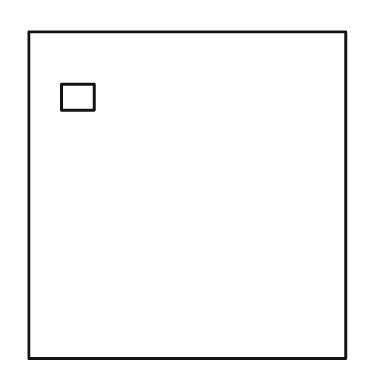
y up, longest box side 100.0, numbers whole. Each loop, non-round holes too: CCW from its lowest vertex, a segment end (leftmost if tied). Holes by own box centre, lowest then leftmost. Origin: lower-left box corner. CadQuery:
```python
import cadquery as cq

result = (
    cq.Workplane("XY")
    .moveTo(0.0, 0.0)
    .lineTo(97.0, 0.0)
    .lineTo(97.0, 100.0)
    .lineTo(0.0, 100.0)
    .close()
    .moveTo(10.0, 76.0)
    .lineTo(20.0, 76.0)
    .lineTo(20.0, 84.0)
    .lineTo(10.0, 84.0)
    .close()
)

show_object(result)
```